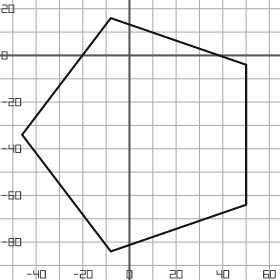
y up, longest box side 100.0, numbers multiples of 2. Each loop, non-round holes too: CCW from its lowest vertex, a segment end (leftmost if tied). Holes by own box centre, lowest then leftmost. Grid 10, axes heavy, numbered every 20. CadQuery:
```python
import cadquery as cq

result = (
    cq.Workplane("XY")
    .moveTo(-8.0, -84.0)
    .lineTo(50.0, -64.0)
    .lineTo(50.0, -4.0)
    .lineTo(-8.0, 16.0)
    .lineTo(-46.0, -34.0)
    .close()
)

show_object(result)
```